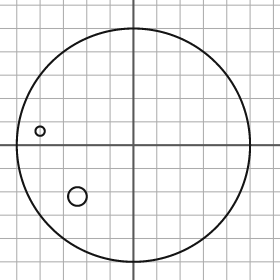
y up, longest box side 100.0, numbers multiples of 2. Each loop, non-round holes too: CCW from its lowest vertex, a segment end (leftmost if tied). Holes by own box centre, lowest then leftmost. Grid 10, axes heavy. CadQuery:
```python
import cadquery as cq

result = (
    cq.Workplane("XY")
    .moveTo(0.0, 0.0)
    .circle(50.0)
    .moveTo(-24.0, -22.0)
    .circle(4.0)
    .moveTo(-40.0, 6.0)
    .circle(2.0)
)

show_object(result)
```